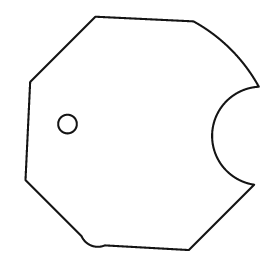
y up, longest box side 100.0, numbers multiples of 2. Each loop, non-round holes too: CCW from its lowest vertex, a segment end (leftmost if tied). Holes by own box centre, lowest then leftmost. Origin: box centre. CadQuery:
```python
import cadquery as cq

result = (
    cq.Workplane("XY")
    .moveTo(20.0, -50.0)
    .lineTo(48.0, -22.0)
    .threePointArc((30.0, 0.0), (50.0, 20.0))
    .threePointArc((38.0, 36.0), (22.0, 48.0))
    .lineTo(-20.0, 50.0)
    .lineTo(-48.0, 22.0)
    .lineTo(-50.0, -20.0)
    .lineTo(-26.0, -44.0)
    .threePointArc((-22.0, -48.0), (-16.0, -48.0))
    .close()
    .moveTo(-32.0, 4.0)
    .circle(4.0)
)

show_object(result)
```